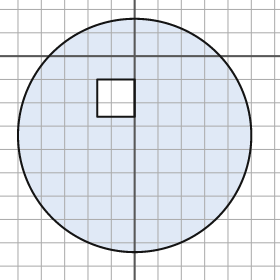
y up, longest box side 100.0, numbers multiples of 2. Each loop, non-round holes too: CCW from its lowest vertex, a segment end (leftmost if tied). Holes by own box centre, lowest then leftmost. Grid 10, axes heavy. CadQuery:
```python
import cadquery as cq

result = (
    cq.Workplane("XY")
    .moveTo(0.0, -34.0)
    .circle(50.0)
    .moveTo(-16.0, -26.0)
    .lineTo(0.0, -26.0)
    .lineTo(0.0, -10.0)
    .lineTo(-16.0, -10.0)
    .close()
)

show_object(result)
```